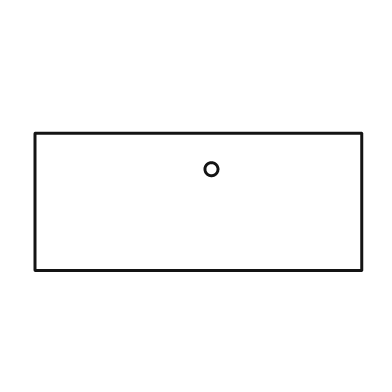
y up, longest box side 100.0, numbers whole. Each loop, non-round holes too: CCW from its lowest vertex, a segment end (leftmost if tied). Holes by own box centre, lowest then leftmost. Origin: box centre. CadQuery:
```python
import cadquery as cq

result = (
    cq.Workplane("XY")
    .moveTo(-50.0, -21.0)
    .lineTo(50.0, -21.0)
    .lineTo(50.0, 21.0)
    .lineTo(-50.0, 21.0)
    .close()
    .moveTo(4.0, 10.0)
    .circle(2.0)
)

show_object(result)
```